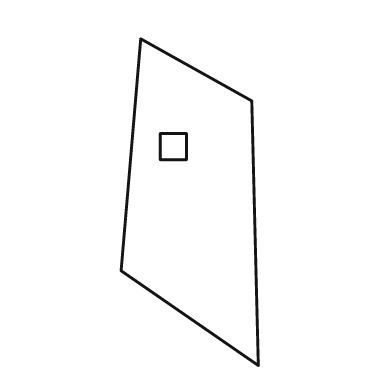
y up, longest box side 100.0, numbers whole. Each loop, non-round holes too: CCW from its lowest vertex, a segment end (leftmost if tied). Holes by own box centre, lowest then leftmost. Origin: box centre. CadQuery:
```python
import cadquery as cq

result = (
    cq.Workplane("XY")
    .moveTo(21.0, -50.0)
    .lineTo(19.0, 31.0)
    .lineTo(-15.0, 50.0)
    .lineTo(-21.0, -21.0)
    .close()
    .moveTo(-9.0, 13.0)
    .lineTo(-1.0, 13.0)
    .lineTo(-1.0, 21.0)
    .lineTo(-9.0, 21.0)
    .close()
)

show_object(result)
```